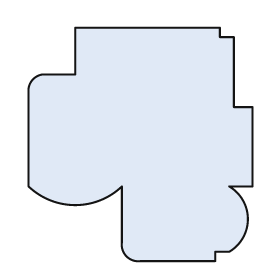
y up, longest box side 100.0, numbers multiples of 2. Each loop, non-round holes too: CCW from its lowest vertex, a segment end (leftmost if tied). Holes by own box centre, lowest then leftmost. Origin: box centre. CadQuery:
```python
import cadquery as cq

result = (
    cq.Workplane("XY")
    .moveTo(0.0, -50.0)
    .lineTo(32.0, -50.0)
    .lineTo(32.0, -46.0)
    .lineTo(38.0, -46.0)
    .threePointArc((46.0, -32.0), (38.0, -18.0))
    .lineTo(48.0, -18.0)
    .lineTo(48.0, 16.0)
    .lineTo(40.0, 16.0)
    .lineTo(40.0, 46.0)
    .lineTo(34.0, 46.0)
    .lineTo(34.0, 50.0)
    .lineTo(-28.0, 50.0)
    .lineTo(-28.0, 30.0)
    .lineTo(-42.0, 30.0)
    .threePointArc((-46.0, 28.0), (-48.0, 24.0))
    .lineTo(-48.0, -18.0)
    .threePointArc((-28.0, -26.0), (-8.0, -18.0))
    .lineTo(-8.0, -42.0)
    .threePointArc((-6.0, -48.0), (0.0, -50.0))
    .close()
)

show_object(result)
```